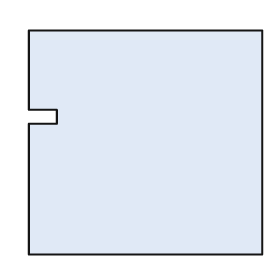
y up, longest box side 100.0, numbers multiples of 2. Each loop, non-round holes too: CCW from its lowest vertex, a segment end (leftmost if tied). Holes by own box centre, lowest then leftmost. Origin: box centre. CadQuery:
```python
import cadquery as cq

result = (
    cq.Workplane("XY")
    .moveTo(-50.0, -48.0)
    .lineTo(50.0, -48.0)
    .lineTo(50.0, 48.0)
    .lineTo(-50.0, 48.0)
    .lineTo(-50.0, 14.0)
    .lineTo(-38.0, 14.0)
    .lineTo(-38.0, 8.0)
    .lineTo(-50.0, 8.0)
    .close()
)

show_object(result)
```